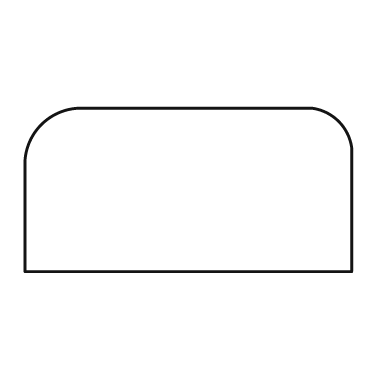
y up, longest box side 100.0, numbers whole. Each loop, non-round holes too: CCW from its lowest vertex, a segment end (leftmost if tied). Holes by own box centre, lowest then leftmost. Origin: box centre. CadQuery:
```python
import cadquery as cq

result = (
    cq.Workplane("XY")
    .moveTo(-50.0, -25.0)
    .lineTo(50.0, -25.0)
    .lineTo(50.0, 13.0)
    .threePointArc((46.0, 21.0), (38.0, 25.0))
    .lineTo(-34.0, 25.0)
    .threePointArc((-45.0, 20.0), (-50.0, 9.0))
    .close()
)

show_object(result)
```